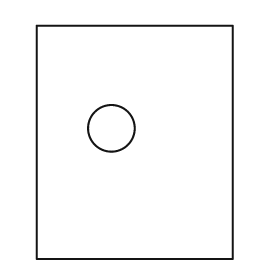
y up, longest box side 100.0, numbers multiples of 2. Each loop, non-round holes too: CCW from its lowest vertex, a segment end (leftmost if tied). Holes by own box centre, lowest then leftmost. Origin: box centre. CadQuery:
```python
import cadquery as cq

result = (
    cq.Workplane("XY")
    .moveTo(-42.0, -50.0)
    .lineTo(42.0, -50.0)
    .lineTo(42.0, 50.0)
    .lineTo(-42.0, 50.0)
    .close()
    .moveTo(-10.0, 6.0)
    .circle(10.0)
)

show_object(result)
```